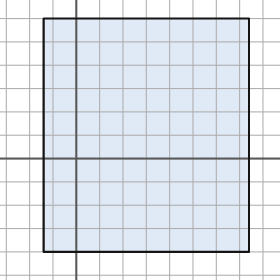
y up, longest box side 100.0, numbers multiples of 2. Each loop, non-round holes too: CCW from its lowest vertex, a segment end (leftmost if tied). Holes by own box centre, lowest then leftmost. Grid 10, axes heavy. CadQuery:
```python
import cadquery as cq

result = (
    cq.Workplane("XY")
    .moveTo(-14.0, -40.0)
    .lineTo(74.0, -40.0)
    .lineTo(74.0, 60.0)
    .lineTo(-14.0, 60.0)
    .close()
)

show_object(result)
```